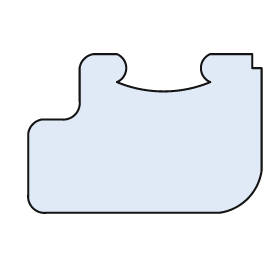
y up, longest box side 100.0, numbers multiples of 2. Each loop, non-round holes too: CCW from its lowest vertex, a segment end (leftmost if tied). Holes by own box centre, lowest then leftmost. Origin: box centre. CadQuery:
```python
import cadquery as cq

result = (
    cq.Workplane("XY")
    .moveTo(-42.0, -34.0)
    .lineTo(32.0, -34.0)
    .threePointArc((44.0, -28.0), (50.0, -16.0))
    .lineTo(50.0, 28.0)
    .lineTo(46.0, 28.0)
    .lineTo(46.0, 34.0)
    .lineTo(28.0, 34.0)
    .threePointArc((24.0, 28.0), (28.0, 22.0))
    .threePointArc((8.0, 18.0), (-12.0, 22.0))
    .threePointArc((-8.0, 28.0), (-12.0, 34.0))
    .lineTo(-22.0, 34.0)
    .threePointArc((-26.0, 32.0), (-28.0, 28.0))
    .lineTo(-28.0, 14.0)
    .threePointArc((-30.0, 8.0), (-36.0, 6.0))
    .lineTo(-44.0, 6.0)
    .threePointArc((-48.0, 4.0), (-50.0, 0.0))
    .lineTo(-50.0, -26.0)
    .threePointArc((-48.0, -32.0), (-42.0, -34.0))
    .close()
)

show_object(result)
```